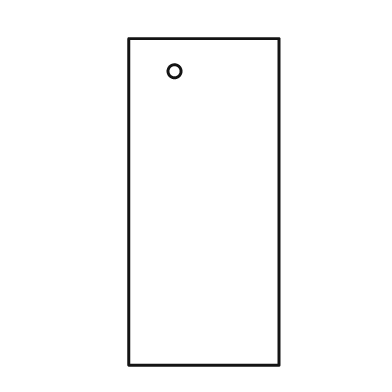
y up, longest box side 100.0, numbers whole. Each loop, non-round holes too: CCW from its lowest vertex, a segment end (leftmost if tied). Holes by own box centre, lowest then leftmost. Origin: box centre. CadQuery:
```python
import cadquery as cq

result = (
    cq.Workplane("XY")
    .moveTo(-23.0, -50.0)
    .lineTo(23.0, -50.0)
    .lineTo(23.0, 50.0)
    .lineTo(-23.0, 50.0)
    .close()
    .moveTo(-9.0, 40.0)
    .circle(2.0)
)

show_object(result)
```